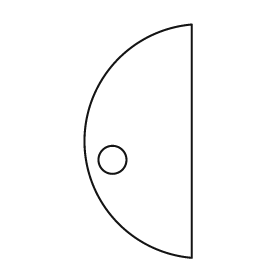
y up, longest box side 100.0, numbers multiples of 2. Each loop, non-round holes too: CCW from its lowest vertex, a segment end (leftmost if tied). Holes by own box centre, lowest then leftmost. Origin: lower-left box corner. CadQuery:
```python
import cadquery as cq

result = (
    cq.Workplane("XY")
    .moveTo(46.0, 0.0)
    .lineTo(46.0, 100.0)
    .threePointArc((0.0, 50.0), (46.0, 0.0))
    .close()
    .moveTo(12.0, 42.0)
    .circle(6.0)
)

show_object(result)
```